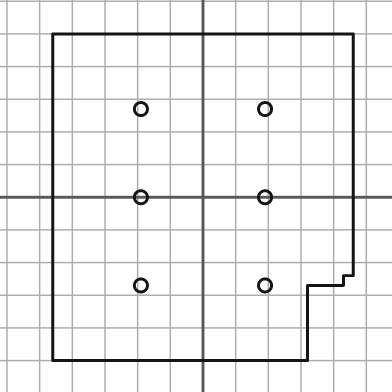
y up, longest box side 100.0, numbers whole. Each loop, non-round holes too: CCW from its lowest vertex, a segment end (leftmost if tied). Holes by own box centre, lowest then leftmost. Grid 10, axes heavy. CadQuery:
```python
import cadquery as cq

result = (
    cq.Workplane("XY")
    .moveTo(-46.0, -50.0)
    .lineTo(32.0, -50.0)
    .lineTo(32.0, -27.0)
    .lineTo(43.0, -27.0)
    .lineTo(43.0, -24.0)
    .lineTo(46.0, -24.0)
    .lineTo(46.0, 50.0)
    .lineTo(-46.0, 50.0)
    .close()
    .moveTo(-19.0, -27.0)
    .circle(2.0)
    .moveTo(19.0, -27.0)
    .circle(2.0)
    .moveTo(-19.0, 0.0)
    .circle(2.0)
    .moveTo(19.0, 0.0)
    .circle(2.0)
    .moveTo(-19.0, 27.0)
    .circle(2.0)
    .moveTo(19.0, 27.0)
    .circle(2.0)
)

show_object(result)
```